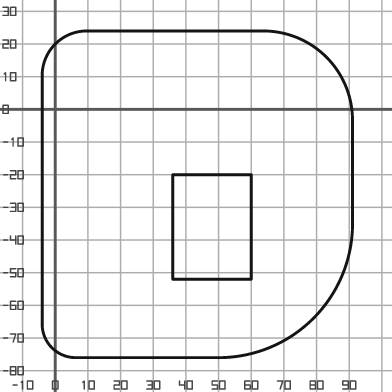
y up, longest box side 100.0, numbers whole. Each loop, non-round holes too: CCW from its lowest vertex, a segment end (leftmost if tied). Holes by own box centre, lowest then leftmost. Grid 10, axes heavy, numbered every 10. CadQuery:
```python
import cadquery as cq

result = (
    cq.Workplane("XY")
    .moveTo(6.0, -76.0)
    .lineTo(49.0, -76.0)
    .threePointArc((79.0, -64.0), (91.0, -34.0))
    .lineTo(91.0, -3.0)
    .threePointArc((83.0, 16.0), (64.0, 24.0))
    .lineTo(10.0, 24.0)
    .threePointArc((0.0, 20.0), (-4.0, 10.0))
    .lineTo(-4.0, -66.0)
    .threePointArc((-1.0, -73.0), (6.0, -76.0))
    .close()
    .moveTo(36.0, -52.0)
    .lineTo(60.0, -52.0)
    .lineTo(60.0, -20.0)
    .lineTo(36.0, -20.0)
    .close()
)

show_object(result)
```